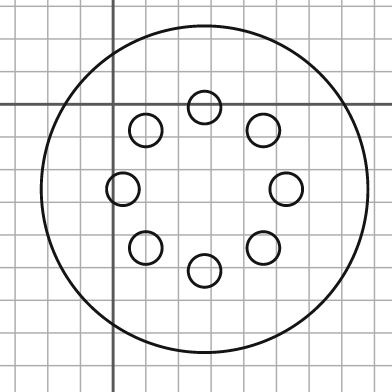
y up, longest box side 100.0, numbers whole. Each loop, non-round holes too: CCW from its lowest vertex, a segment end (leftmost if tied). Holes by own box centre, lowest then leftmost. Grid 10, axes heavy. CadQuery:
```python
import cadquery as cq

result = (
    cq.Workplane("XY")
    .moveTo(28.0, -26.0)
    .circle(50.0)
    .moveTo(28.0, -51.0)
    .circle(5.0)
    .moveTo(10.0, -44.0)
    .circle(5.0)
    .moveTo(46.0, -44.0)
    .circle(5.0)
    .moveTo(3.0, -26.0)
    .circle(5.0)
    .moveTo(53.0, -26.0)
    .circle(5.0)
    .moveTo(10.0, -8.0)
    .circle(5.0)
    .moveTo(46.0, -8.0)
    .circle(5.0)
    .moveTo(28.0, -1.0)
    .circle(5.0)
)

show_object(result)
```